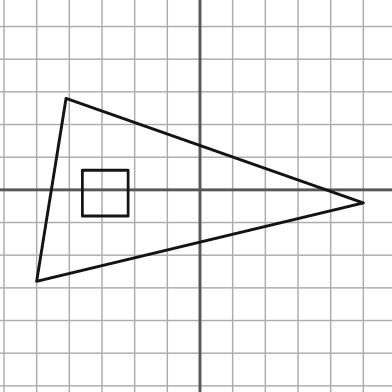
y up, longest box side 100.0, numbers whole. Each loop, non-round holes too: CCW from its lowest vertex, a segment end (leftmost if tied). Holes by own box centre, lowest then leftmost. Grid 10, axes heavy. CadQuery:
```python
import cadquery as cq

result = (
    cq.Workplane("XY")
    .moveTo(-50.0, -28.0)
    .lineTo(50.0, -4.0)
    .lineTo(-41.0, 28.0)
    .close()
    .moveTo(-36.0, -8.0)
    .lineTo(-22.0, -8.0)
    .lineTo(-22.0, 6.0)
    .lineTo(-36.0, 6.0)
    .close()
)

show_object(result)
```